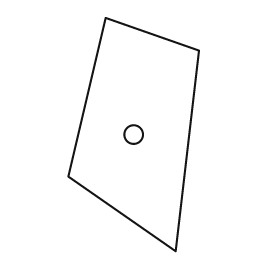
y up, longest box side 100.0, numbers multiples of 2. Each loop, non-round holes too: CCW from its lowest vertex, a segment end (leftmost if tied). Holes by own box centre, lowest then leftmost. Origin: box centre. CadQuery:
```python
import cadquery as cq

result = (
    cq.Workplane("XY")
    .moveTo(18.0, -50.0)
    .lineTo(28.0, 36.0)
    .lineTo(-12.0, 50.0)
    .lineTo(-28.0, -18.0)
    .close()
    .moveTo(0.0, 0.0)
    .circle(4.0)
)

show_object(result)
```